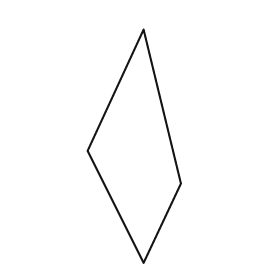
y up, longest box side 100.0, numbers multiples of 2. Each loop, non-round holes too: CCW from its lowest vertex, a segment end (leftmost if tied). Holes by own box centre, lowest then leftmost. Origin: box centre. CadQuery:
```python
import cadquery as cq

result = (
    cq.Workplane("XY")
    .moveTo(4.0, -50.0)
    .lineTo(20.0, -16.0)
    .lineTo(4.0, 50.0)
    .lineTo(-20.0, -2.0)
    .close()
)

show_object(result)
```